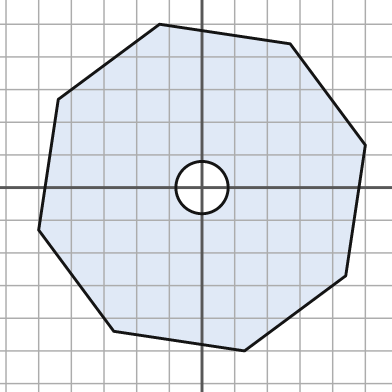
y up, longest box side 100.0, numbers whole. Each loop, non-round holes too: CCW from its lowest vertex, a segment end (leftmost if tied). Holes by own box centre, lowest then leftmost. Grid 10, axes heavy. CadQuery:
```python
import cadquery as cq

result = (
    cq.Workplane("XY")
    .moveTo(13.0, -50.0)
    .lineTo(44.0, -27.0)
    .lineTo(50.0, 13.0)
    .lineTo(27.0, 44.0)
    .lineTo(-13.0, 50.0)
    .lineTo(-44.0, 27.0)
    .lineTo(-50.0, -13.0)
    .lineTo(-27.0, -44.0)
    .close()
    .moveTo(0.0, 0.0)
    .circle(8.0)
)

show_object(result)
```